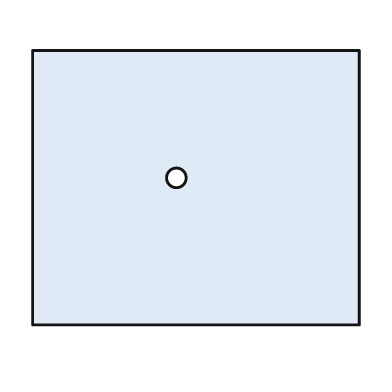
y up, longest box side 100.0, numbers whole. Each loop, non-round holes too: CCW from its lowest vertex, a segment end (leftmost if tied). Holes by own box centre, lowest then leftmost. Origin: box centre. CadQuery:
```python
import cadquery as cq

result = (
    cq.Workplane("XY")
    .moveTo(-50.0, -42.0)
    .lineTo(50.0, -42.0)
    .lineTo(50.0, 42.0)
    .lineTo(-50.0, 42.0)
    .close()
    .moveTo(-6.0, 3.0)
    .circle(3.0)
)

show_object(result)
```